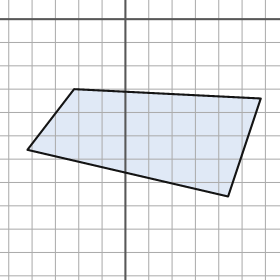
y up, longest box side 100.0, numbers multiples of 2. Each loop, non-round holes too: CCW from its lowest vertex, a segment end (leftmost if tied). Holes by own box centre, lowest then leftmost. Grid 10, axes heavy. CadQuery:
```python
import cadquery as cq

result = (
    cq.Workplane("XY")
    .moveTo(44.0, -76.0)
    .lineTo(58.0, -34.0)
    .lineTo(-22.0, -30.0)
    .lineTo(-42.0, -56.0)
    .close()
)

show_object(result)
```